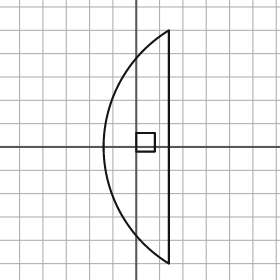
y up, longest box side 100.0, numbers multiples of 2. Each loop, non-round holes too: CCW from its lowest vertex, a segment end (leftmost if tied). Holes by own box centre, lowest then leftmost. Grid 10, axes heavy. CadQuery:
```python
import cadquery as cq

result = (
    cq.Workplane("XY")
    .moveTo(14.0, -50.0)
    .lineTo(14.0, 50.0)
    .threePointArc((-14.0, 0.0), (14.0, -50.0))
    .close()
    .moveTo(0.0, -2.0)
    .lineTo(8.0, -2.0)
    .lineTo(8.0, 6.0)
    .lineTo(0.0, 6.0)
    .close()
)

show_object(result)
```